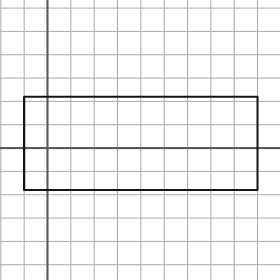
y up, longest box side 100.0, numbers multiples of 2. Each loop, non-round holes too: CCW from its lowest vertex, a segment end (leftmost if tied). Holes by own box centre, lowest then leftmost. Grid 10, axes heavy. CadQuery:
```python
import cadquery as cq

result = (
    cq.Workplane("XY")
    .moveTo(-10.0, -18.0)
    .lineTo(90.0, -18.0)
    .lineTo(90.0, 22.0)
    .lineTo(-10.0, 22.0)
    .close()
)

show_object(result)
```